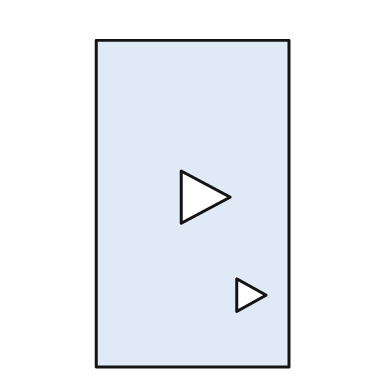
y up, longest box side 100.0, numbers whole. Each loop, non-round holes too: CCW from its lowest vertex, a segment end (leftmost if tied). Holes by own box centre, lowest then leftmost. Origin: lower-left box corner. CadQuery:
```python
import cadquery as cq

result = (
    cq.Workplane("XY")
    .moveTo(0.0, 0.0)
    .lineTo(59.0, 0.0)
    .lineTo(59.0, 100.0)
    .lineTo(0.0, 100.0)
    .close()
    .moveTo(43.0, 17.0)
    .lineTo(52.0, 22.0)
    .lineTo(43.0, 27.0)
    .close()
    .moveTo(26.0, 44.0)
    .lineTo(41.0, 52.0)
    .lineTo(26.0, 60.0)
    .close()
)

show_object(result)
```